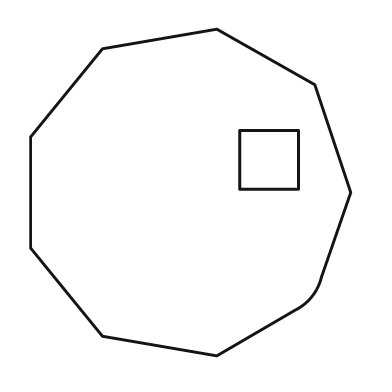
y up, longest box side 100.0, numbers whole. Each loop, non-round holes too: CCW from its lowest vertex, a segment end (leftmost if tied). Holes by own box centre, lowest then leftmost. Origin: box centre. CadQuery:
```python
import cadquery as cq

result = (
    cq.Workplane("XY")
    .moveTo(8.0, -50.0)
    .lineTo(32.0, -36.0)
    .threePointArc((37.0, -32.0), (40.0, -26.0))
    .lineTo(49.0, 0.0)
    .lineTo(38.0, 33.0)
    .lineTo(8.0, 50.0)
    .lineTo(-27.0, 44.0)
    .lineTo(-49.0, 17.0)
    .lineTo(-49.0, -17.0)
    .lineTo(-27.0, -44.0)
    .close()
    .moveTo(15.0, 1.0)
    .lineTo(33.0, 1.0)
    .lineTo(33.0, 19.0)
    .lineTo(15.0, 19.0)
    .close()
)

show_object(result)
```